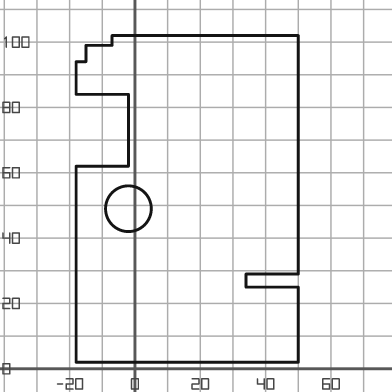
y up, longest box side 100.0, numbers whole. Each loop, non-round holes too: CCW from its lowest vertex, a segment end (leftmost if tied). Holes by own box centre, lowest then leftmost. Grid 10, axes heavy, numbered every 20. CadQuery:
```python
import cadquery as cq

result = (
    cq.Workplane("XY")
    .moveTo(-18.0, 2.0)
    .lineTo(50.0, 2.0)
    .lineTo(50.0, 25.0)
    .lineTo(34.0, 25.0)
    .lineTo(34.0, 29.0)
    .lineTo(50.0, 29.0)
    .lineTo(50.0, 102.0)
    .lineTo(-7.0, 102.0)
    .lineTo(-7.0, 99.0)
    .lineTo(-15.0, 99.0)
    .lineTo(-15.0, 94.0)
    .lineTo(-18.0, 94.0)
    .lineTo(-18.0, 84.0)
    .lineTo(-2.0, 84.0)
    .lineTo(-2.0, 62.0)
    .lineTo(-18.0, 62.0)
    .close()
    .moveTo(-2.0, 49.0)
    .circle(7.0)
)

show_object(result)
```